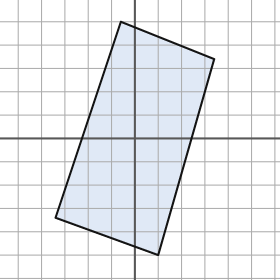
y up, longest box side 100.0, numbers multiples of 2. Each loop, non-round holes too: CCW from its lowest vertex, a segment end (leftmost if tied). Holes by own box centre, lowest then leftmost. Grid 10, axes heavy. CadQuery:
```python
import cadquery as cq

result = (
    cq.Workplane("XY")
    .moveTo(10.0, -50.0)
    .lineTo(34.0, 34.0)
    .lineTo(-6.0, 50.0)
    .lineTo(-34.0, -34.0)
    .close()
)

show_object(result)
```